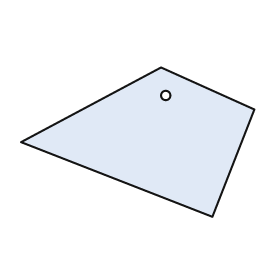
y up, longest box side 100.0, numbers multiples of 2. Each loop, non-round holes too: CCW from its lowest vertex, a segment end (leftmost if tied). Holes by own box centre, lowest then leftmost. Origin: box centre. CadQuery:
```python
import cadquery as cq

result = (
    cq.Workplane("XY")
    .moveTo(32.0, -32.0)
    .lineTo(50.0, 14.0)
    .lineTo(10.0, 32.0)
    .lineTo(-50.0, 0.0)
    .close()
    .moveTo(12.0, 20.0)
    .circle(2.0)
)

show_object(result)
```